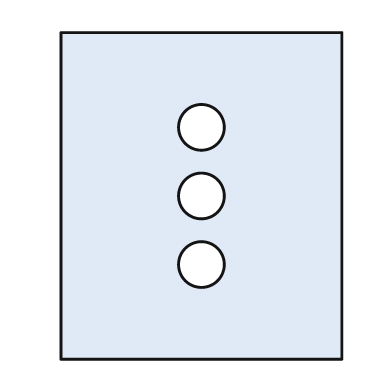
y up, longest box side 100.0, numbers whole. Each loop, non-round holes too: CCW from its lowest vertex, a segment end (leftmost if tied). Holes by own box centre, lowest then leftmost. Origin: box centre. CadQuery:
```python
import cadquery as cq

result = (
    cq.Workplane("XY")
    .moveTo(-43.0, -50.0)
    .lineTo(43.0, -50.0)
    .lineTo(43.0, 50.0)
    .lineTo(-43.0, 50.0)
    .close()
    .moveTo(0.0, -21.0)
    .circle(7.0)
    .moveTo(0.0, 0.0)
    .circle(7.0)
    .moveTo(0.0, 21.0)
    .circle(7.0)
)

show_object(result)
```